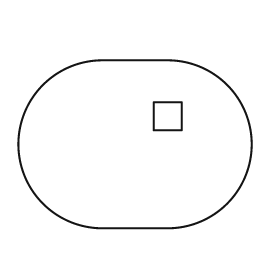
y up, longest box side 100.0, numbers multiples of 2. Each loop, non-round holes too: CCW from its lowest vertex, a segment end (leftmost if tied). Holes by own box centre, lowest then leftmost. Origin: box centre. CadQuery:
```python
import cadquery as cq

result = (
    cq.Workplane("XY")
    .moveTo(-14.0, -36.0)
    .lineTo(14.0, -36.0)
    .threePointArc((50.0, 0.0), (14.0, 36.0))
    .lineTo(-14.0, 36.0)
    .threePointArc((-50.0, 0.0), (-14.0, -36.0))
    .close()
    .moveTo(8.0, 6.0)
    .lineTo(20.0, 6.0)
    .lineTo(20.0, 18.0)
    .lineTo(8.0, 18.0)
    .close()
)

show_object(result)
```